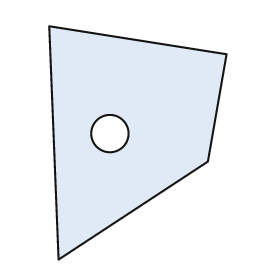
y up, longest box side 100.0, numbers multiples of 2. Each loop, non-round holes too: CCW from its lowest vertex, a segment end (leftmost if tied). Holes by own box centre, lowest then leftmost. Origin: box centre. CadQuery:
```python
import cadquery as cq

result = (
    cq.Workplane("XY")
    .moveTo(-34.0, -50.0)
    .lineTo(30.0, -8.0)
    .lineTo(38.0, 38.0)
    .lineTo(-38.0, 50.0)
    .close()
    .moveTo(-12.0, 4.0)
    .circle(8.0)
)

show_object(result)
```